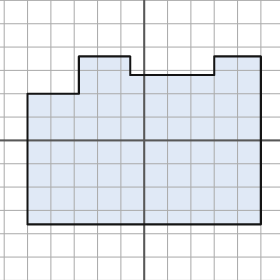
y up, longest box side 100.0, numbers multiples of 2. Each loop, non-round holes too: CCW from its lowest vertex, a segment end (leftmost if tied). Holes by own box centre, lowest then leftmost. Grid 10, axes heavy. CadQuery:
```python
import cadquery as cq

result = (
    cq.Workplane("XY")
    .moveTo(-50.0, -36.0)
    .lineTo(50.0, -36.0)
    .lineTo(50.0, 36.0)
    .lineTo(30.0, 36.0)
    .lineTo(30.0, 28.0)
    .lineTo(-6.0, 28.0)
    .lineTo(-6.0, 36.0)
    .lineTo(-28.0, 36.0)
    .lineTo(-28.0, 20.0)
    .lineTo(-50.0, 20.0)
    .close()
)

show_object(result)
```